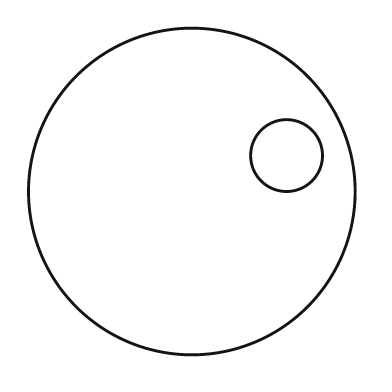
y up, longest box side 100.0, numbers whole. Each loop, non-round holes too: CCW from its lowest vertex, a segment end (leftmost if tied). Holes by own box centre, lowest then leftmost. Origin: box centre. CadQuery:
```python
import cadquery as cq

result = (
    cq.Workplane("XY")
    .moveTo(0.0, 0.0)
    .circle(50.0)
    .moveTo(29.0, 11.0)
    .circle(11.0)
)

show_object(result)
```